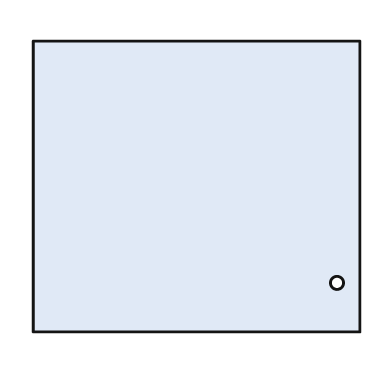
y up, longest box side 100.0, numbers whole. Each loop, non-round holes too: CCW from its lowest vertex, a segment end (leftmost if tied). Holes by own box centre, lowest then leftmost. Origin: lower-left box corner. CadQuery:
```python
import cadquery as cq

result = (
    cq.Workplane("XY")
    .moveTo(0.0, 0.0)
    .lineTo(100.0, 0.0)
    .lineTo(100.0, 89.0)
    .lineTo(0.0, 89.0)
    .close()
    .moveTo(93.0, 15.0)
    .circle(2.0)
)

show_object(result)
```